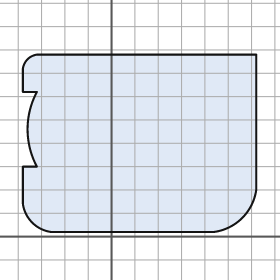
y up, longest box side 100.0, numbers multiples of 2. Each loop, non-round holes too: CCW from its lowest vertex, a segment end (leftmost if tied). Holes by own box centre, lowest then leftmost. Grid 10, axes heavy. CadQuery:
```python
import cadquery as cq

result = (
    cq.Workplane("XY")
    .moveTo(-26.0, 2.0)
    .lineTo(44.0, 2.0)
    .threePointArc((56.0, 8.0), (62.0, 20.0))
    .lineTo(62.0, 78.0)
    .lineTo(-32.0, 78.0)
    .threePointArc((-36.0, 76.0), (-38.0, 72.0))
    .lineTo(-38.0, 62.0)
    .lineTo(-32.0, 62.0)
    .threePointArc((-36.0, 46.0), (-32.0, 30.0))
    .lineTo(-38.0, 30.0)
    .lineTo(-38.0, 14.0)
    .threePointArc((-34.0, 6.0), (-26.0, 2.0))
    .close()
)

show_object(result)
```